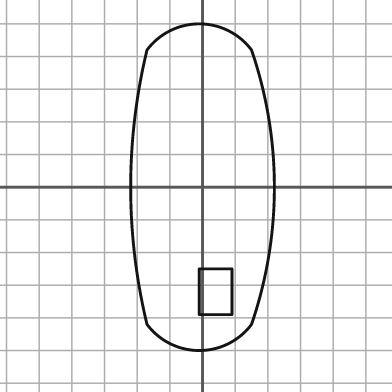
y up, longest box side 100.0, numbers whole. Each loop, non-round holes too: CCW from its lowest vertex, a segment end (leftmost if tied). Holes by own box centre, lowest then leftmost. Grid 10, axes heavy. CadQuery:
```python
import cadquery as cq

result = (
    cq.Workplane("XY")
    .moveTo(-17.0, -42.0)
    .threePointArc((-1.0, -50.0), (15.0, -42.0))
    .threePointArc((22.0, 0.0), (15.0, 42.0))
    .threePointArc((-1.0, 50.0), (-17.0, 42.0))
    .threePointArc((-22.0, 0.0), (-17.0, -42.0))
    .close()
    .moveTo(-1.0, -39.0)
    .lineTo(9.0, -39.0)
    .lineTo(9.0, -25.0)
    .lineTo(-1.0, -25.0)
    .close()
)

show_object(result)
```